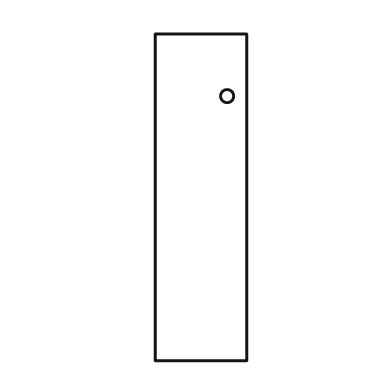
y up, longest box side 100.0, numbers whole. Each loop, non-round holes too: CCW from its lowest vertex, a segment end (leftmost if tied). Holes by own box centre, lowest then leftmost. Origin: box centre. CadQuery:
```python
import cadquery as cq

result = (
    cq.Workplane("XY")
    .moveTo(-14.0, -50.0)
    .lineTo(14.0, -50.0)
    .lineTo(14.0, 50.0)
    .lineTo(-14.0, 50.0)
    .close()
    .moveTo(8.0, 31.0)
    .circle(2.0)
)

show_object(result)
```